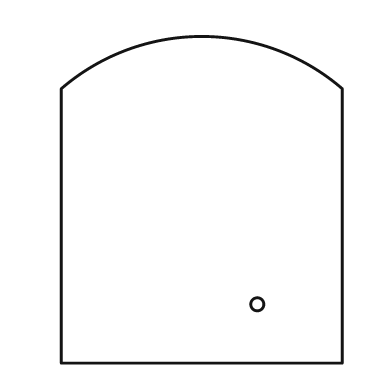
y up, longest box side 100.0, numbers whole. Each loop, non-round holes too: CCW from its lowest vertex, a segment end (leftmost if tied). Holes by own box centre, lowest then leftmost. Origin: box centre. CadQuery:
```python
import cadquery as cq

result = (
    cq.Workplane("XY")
    .moveTo(-43.0, -50.0)
    .lineTo(43.0, -50.0)
    .lineTo(43.0, 34.0)
    .threePointArc((0.0, 50.0), (-43.0, 34.0))
    .close()
    .moveTo(17.0, -32.0)
    .circle(2.0)
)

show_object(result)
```